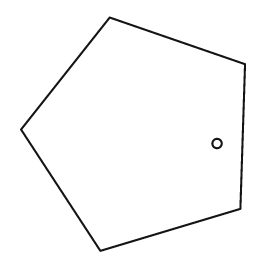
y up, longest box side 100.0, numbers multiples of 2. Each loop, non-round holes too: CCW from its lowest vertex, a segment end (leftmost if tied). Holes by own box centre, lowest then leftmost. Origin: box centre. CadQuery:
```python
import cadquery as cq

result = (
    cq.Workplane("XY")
    .moveTo(-14.0, -50.0)
    .lineTo(46.0, -32.0)
    .lineTo(48.0, 30.0)
    .lineTo(-10.0, 50.0)
    .lineTo(-48.0, 2.0)
    .close()
    .moveTo(36.0, -4.0)
    .circle(2.0)
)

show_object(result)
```